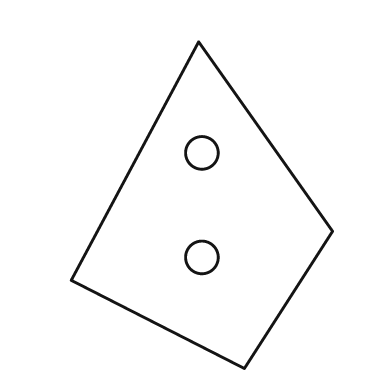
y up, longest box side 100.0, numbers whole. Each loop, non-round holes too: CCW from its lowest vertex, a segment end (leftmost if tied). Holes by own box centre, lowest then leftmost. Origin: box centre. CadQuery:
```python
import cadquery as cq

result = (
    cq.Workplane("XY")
    .moveTo(13.0, -50.0)
    .lineTo(40.0, -8.0)
    .lineTo(-1.0, 50.0)
    .lineTo(-40.0, -23.0)
    .close()
    .moveTo(0.0, -16.0)
    .circle(5.0)
    .moveTo(0.0, 16.0)
    .circle(5.0)
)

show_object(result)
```